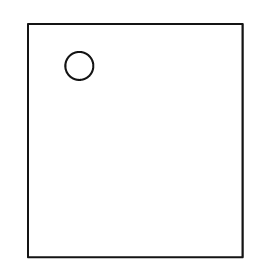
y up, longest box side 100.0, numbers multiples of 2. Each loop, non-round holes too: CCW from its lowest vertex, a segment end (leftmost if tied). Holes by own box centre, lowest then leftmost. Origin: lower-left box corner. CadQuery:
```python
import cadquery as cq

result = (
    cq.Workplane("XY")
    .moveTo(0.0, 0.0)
    .lineTo(92.0, 0.0)
    .lineTo(92.0, 100.0)
    .lineTo(0.0, 100.0)
    .close()
    .moveTo(22.0, 82.0)
    .circle(6.0)
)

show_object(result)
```